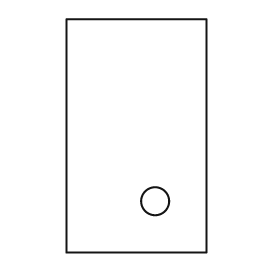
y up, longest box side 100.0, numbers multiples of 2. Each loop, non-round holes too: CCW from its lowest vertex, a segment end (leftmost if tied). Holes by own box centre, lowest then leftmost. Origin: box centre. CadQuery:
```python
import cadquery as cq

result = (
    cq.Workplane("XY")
    .moveTo(-30.0, -50.0)
    .lineTo(30.0, -50.0)
    .lineTo(30.0, 50.0)
    .lineTo(-30.0, 50.0)
    .close()
    .moveTo(8.0, -28.0)
    .circle(6.0)
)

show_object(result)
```